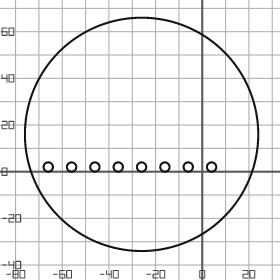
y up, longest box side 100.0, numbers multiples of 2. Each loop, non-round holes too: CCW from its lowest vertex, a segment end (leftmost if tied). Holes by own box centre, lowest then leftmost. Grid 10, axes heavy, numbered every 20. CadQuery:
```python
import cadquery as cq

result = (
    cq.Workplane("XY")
    .moveTo(-26.0, 16.0)
    .circle(50.0)
    .moveTo(-66.0, 2.0)
    .circle(2.0)
    .moveTo(-56.0, 2.0)
    .circle(2.0)
    .moveTo(-46.0, 2.0)
    .circle(2.0)
    .moveTo(-36.0, 2.0)
    .circle(2.0)
    .moveTo(-26.0, 2.0)
    .circle(2.0)
    .moveTo(-16.0, 2.0)
    .circle(2.0)
    .moveTo(-6.0, 2.0)
    .circle(2.0)
    .moveTo(4.0, 2.0)
    .circle(2.0)
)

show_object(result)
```